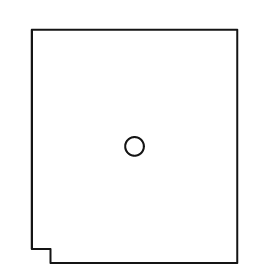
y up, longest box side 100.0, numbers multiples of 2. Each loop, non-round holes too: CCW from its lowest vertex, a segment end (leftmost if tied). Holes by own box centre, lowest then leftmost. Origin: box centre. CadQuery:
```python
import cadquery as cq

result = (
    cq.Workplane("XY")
    .moveTo(-36.0, -50.0)
    .lineTo(44.0, -50.0)
    .lineTo(44.0, 50.0)
    .lineTo(-44.0, 50.0)
    .lineTo(-44.0, -44.0)
    .lineTo(-36.0, -44.0)
    .close()
    .moveTo(0.0, 0.0)
    .circle(4.0)
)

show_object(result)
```